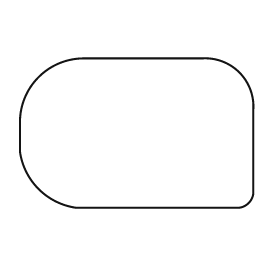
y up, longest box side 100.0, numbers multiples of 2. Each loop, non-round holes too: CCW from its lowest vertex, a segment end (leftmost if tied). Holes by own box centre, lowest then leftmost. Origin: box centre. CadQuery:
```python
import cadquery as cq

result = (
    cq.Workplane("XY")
    .moveTo(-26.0, -32.0)
    .lineTo(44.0, -32.0)
    .threePointArc((48.0, -30.0), (50.0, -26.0))
    .lineTo(50.0, 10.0)
    .threePointArc((44.0, 26.0), (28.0, 32.0))
    .lineTo(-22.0, 32.0)
    .threePointArc((-42.0, 24.0), (-50.0, 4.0))
    .lineTo(-50.0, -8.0)
    .threePointArc((-42.0, -24.0), (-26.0, -32.0))
    .close()
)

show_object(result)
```